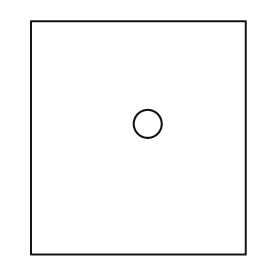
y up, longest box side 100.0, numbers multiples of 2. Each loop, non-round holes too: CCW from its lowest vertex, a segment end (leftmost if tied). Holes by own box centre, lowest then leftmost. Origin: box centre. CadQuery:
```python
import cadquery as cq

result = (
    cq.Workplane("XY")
    .moveTo(-46.0, -50.0)
    .lineTo(46.0, -50.0)
    .lineTo(46.0, 50.0)
    .lineTo(-46.0, 50.0)
    .close()
    .moveTo(4.0, 6.0)
    .circle(6.0)
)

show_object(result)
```